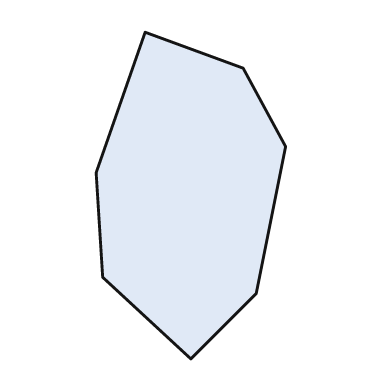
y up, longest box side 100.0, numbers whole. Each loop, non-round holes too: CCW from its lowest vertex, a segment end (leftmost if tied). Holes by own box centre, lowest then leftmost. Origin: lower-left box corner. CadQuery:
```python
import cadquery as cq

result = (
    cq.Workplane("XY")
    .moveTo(29.0, 0.0)
    .lineTo(49.0, 20.0)
    .lineTo(58.0, 65.0)
    .lineTo(45.0, 89.0)
    .lineTo(15.0, 100.0)
    .lineTo(0.0, 57.0)
    .lineTo(2.0, 25.0)
    .close()
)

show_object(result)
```